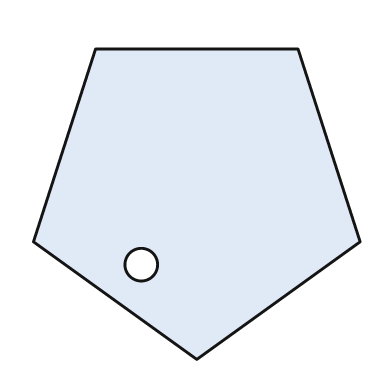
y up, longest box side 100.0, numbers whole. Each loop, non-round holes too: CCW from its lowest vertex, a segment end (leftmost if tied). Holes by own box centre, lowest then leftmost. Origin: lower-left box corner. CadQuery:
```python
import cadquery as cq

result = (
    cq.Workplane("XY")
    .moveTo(50.0, 0.0)
    .lineTo(100.0, 36.0)
    .lineTo(81.0, 95.0)
    .lineTo(19.0, 95.0)
    .lineTo(0.0, 36.0)
    .close()
    .moveTo(33.0, 29.0)
    .circle(5.0)
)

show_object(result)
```